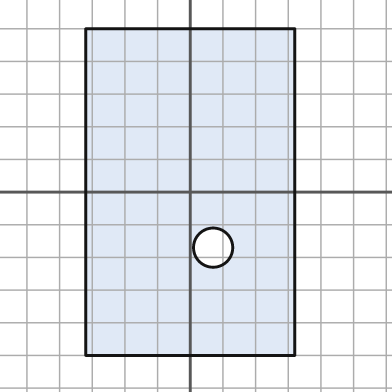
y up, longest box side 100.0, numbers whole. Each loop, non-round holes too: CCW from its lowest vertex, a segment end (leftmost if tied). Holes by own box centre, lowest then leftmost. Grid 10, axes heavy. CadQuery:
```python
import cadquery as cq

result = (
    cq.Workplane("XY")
    .moveTo(-32.0, -50.0)
    .lineTo(32.0, -50.0)
    .lineTo(32.0, 50.0)
    .lineTo(-32.0, 50.0)
    .close()
    .moveTo(7.0, -17.0)
    .circle(6.0)
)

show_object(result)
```